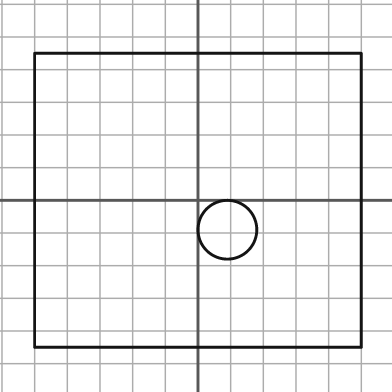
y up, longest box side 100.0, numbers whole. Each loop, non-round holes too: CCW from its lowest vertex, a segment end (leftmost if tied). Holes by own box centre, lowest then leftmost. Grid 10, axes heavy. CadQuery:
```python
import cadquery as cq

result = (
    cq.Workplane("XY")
    .moveTo(-50.0, -45.0)
    .lineTo(50.0, -45.0)
    .lineTo(50.0, 45.0)
    .lineTo(-50.0, 45.0)
    .close()
    .moveTo(9.0, -9.0)
    .circle(9.0)
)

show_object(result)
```